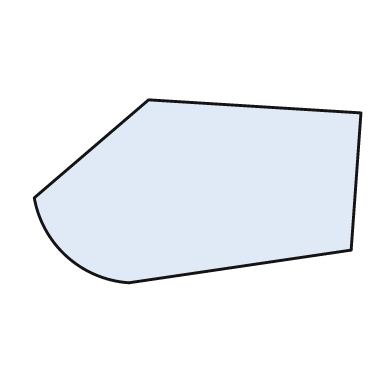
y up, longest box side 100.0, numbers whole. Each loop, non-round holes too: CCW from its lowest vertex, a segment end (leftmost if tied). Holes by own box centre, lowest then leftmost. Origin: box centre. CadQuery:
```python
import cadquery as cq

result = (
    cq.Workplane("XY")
    .moveTo(-21.0, -28.0)
    .lineTo(47.0, -18.0)
    .lineTo(50.0, 24.0)
    .lineTo(-15.0, 28.0)
    .lineTo(-50.0, -2.0)
    .threePointArc((-40.0, -20.0), (-21.0, -28.0))
    .close()
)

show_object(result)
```